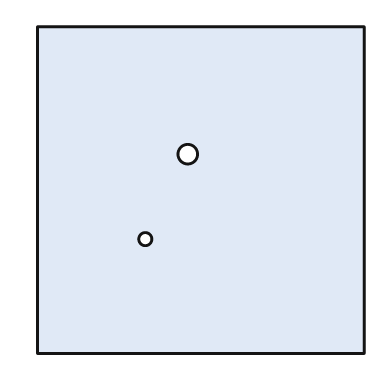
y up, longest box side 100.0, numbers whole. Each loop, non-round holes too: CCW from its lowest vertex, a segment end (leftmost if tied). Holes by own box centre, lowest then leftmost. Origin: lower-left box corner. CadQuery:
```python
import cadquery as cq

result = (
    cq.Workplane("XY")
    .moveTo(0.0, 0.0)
    .lineTo(100.0, 0.0)
    .lineTo(100.0, 100.0)
    .lineTo(0.0, 100.0)
    .close()
    .moveTo(33.0, 35.0)
    .circle(2.0)
    .moveTo(46.0, 61.0)
    .circle(3.0)
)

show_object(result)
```